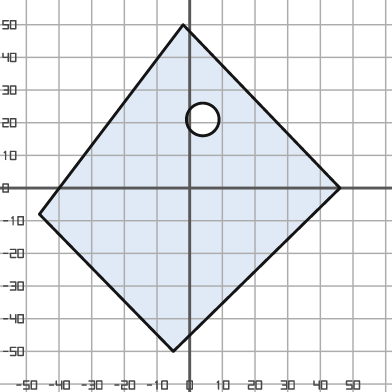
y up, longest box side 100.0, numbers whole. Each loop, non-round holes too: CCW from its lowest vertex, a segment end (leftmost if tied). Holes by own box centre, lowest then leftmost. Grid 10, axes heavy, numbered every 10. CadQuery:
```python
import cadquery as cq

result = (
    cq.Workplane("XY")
    .moveTo(-5.0, -50.0)
    .lineTo(46.0, 0.0)
    .lineTo(-2.0, 50.0)
    .lineTo(-46.0, -8.0)
    .close()
    .moveTo(4.0, 21.0)
    .circle(5.0)
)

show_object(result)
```